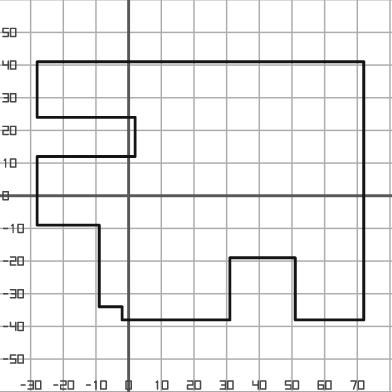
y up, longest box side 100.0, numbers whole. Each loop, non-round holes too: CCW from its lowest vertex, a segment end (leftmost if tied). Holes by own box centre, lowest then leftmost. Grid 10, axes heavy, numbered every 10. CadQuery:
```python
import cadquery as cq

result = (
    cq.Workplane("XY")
    .moveTo(-2.0, -38.0)
    .lineTo(31.0, -38.0)
    .lineTo(31.0, -19.0)
    .lineTo(51.0, -19.0)
    .lineTo(51.0, -38.0)
    .lineTo(72.0, -38.0)
    .lineTo(72.0, 41.0)
    .lineTo(-28.0, 41.0)
    .lineTo(-28.0, 24.0)
    .lineTo(2.0, 24.0)
    .lineTo(2.0, 12.0)
    .lineTo(-28.0, 12.0)
    .lineTo(-28.0, -9.0)
    .lineTo(-9.0, -9.0)
    .lineTo(-9.0, -34.0)
    .lineTo(-2.0, -34.0)
    .close()
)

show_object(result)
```